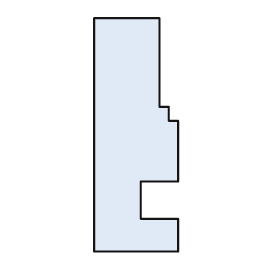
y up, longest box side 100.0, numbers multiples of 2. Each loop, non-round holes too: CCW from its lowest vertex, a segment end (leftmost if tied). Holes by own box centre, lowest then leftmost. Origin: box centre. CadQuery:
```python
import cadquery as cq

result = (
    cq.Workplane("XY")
    .moveTo(-18.0, -50.0)
    .lineTo(18.0, -50.0)
    .lineTo(18.0, -36.0)
    .lineTo(2.0, -36.0)
    .lineTo(2.0, -20.0)
    .lineTo(18.0, -20.0)
    .lineTo(18.0, 6.0)
    .lineTo(14.0, 6.0)
    .lineTo(14.0, 12.0)
    .lineTo(10.0, 12.0)
    .lineTo(10.0, 50.0)
    .lineTo(-18.0, 50.0)
    .close()
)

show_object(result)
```